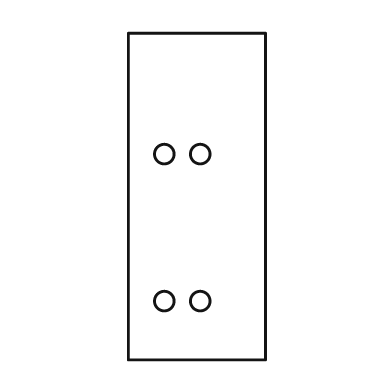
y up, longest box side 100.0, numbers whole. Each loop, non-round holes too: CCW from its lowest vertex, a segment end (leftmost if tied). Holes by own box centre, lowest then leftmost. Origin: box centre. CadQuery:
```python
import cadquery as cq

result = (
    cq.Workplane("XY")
    .moveTo(-21.0, -50.0)
    .lineTo(21.0, -50.0)
    .lineTo(21.0, 50.0)
    .lineTo(-21.0, 50.0)
    .close()
    .moveTo(-10.0, -32.0)
    .circle(3.0)
    .moveTo(1.0, -32.0)
    .circle(3.0)
    .moveTo(-10.0, 13.0)
    .circle(3.0)
    .moveTo(1.0, 13.0)
    .circle(3.0)
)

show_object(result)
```